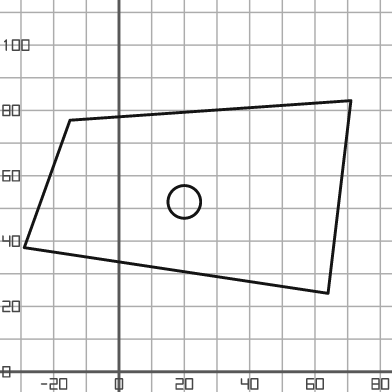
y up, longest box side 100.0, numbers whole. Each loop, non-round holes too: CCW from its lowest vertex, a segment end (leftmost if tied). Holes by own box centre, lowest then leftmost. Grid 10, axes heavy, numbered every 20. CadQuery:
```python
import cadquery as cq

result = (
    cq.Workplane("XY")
    .moveTo(64.0, 24.0)
    .lineTo(71.0, 83.0)
    .lineTo(-15.0, 77.0)
    .lineTo(-29.0, 38.0)
    .close()
    .moveTo(20.0, 52.0)
    .circle(5.0)
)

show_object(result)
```